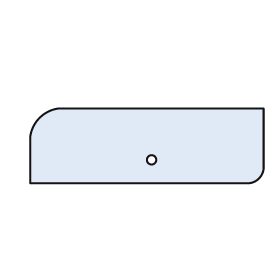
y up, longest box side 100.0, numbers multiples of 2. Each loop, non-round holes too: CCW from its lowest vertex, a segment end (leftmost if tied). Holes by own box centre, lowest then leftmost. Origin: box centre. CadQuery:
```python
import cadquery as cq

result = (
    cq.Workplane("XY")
    .moveTo(-50.0, -16.0)
    .lineTo(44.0, -16.0)
    .threePointArc((48.0, -14.0), (50.0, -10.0))
    .lineTo(50.0, 16.0)
    .lineTo(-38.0, 16.0)
    .threePointArc((-46.0, 12.0), (-50.0, 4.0))
    .close()
    .moveTo(2.0, -6.0)
    .circle(2.0)
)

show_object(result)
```